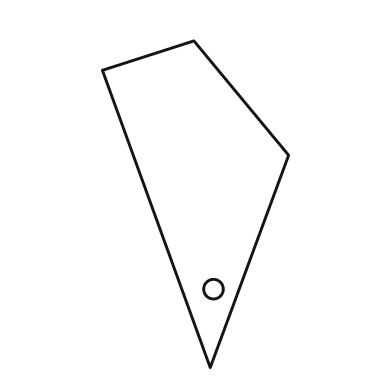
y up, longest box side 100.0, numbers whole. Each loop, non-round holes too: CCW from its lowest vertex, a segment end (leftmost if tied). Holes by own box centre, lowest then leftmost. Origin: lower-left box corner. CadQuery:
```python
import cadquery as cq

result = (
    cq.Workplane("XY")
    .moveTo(33.0, 0.0)
    .lineTo(57.0, 65.0)
    .lineTo(28.0, 100.0)
    .lineTo(0.0, 91.0)
    .close()
    .moveTo(34.0, 24.0)
    .circle(3.0)
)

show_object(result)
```